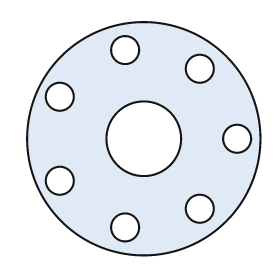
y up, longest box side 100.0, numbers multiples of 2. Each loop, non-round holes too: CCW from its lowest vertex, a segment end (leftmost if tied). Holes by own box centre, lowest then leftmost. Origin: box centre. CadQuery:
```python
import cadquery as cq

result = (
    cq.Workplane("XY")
    .moveTo(0.0, 0.0)
    .circle(50.0)
    .moveTo(-8.0, -38.0)
    .circle(6.0)
    .moveTo(24.0, -30.0)
    .circle(6.0)
    .moveTo(-36.0, -18.0)
    .circle(6.0)
    .moveTo(0.0, 0.0)
    .circle(16.0)
    .moveTo(40.0, 0.0)
    .circle(6.0)
    .moveTo(-36.0, 18.0)
    .circle(6.0)
    .moveTo(24.0, 30.0)
    .circle(6.0)
    .moveTo(-8.0, 38.0)
    .circle(6.0)
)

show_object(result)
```